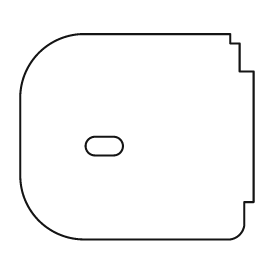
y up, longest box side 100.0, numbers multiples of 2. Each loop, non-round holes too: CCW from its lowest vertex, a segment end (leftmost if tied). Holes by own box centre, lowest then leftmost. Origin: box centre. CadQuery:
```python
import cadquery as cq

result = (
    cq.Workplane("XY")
    .moveTo(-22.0, -44.0)
    .lineTo(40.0, -44.0)
    .threePointArc((44.0, -42.0), (46.0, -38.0))
    .lineTo(46.0, -28.0)
    .lineTo(50.0, -28.0)
    .lineTo(50.0, 28.0)
    .lineTo(44.0, 28.0)
    .lineTo(44.0, 40.0)
    .lineTo(40.0, 40.0)
    .lineTo(40.0, 44.0)
    .lineTo(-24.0, 44.0)
    .threePointArc((-42.0, 36.0), (-50.0, 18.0))
    .lineTo(-50.0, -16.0)
    .threePointArc((-42.0, -36.0), (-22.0, -44.0))
    .close()
    .moveTo(-18.0, -8.0)
    .lineTo(-10.0, -8.0)
    .threePointArc((-6.0, -4.0), (-10.0, 0.0))
    .lineTo(-18.0, 0.0)
    .threePointArc((-22.0, -4.0), (-18.0, -8.0))
    .close()
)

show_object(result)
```